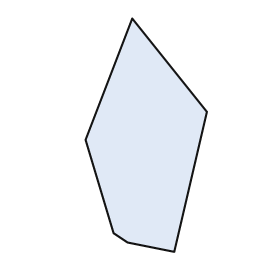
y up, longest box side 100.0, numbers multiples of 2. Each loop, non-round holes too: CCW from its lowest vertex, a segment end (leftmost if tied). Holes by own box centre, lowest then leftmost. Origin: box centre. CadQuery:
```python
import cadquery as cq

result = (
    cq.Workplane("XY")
    .moveTo(12.0, -50.0)
    .lineTo(26.0, 10.0)
    .lineTo(-6.0, 50.0)
    .lineTo(-26.0, -2.0)
    .lineTo(-14.0, -42.0)
    .lineTo(-8.0, -46.0)
    .close()
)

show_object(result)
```